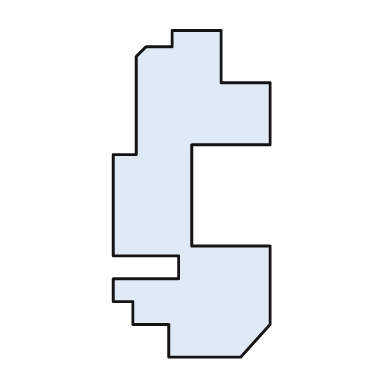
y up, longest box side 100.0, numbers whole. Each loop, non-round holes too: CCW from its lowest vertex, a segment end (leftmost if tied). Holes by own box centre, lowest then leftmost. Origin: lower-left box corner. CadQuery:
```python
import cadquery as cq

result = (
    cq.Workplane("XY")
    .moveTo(17.0, 0.0)
    .lineTo(39.0, 0.0)
    .lineTo(48.0, 10.0)
    .lineTo(48.0, 34.0)
    .lineTo(24.0, 34.0)
    .lineTo(24.0, 65.0)
    .lineTo(48.0, 65.0)
    .lineTo(48.0, 84.0)
    .lineTo(33.0, 84.0)
    .lineTo(33.0, 100.0)
    .lineTo(18.0, 100.0)
    .lineTo(18.0, 95.0)
    .lineTo(10.0, 95.0)
    .lineTo(7.0, 92.0)
    .lineTo(7.0, 62.0)
    .lineTo(0.0, 62.0)
    .lineTo(0.0, 31.0)
    .lineTo(20.0, 31.0)
    .lineTo(20.0, 24.0)
    .lineTo(0.0, 24.0)
    .lineTo(0.0, 17.0)
    .lineTo(6.0, 17.0)
    .lineTo(6.0, 10.0)
    .lineTo(17.0, 10.0)
    .close()
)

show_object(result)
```